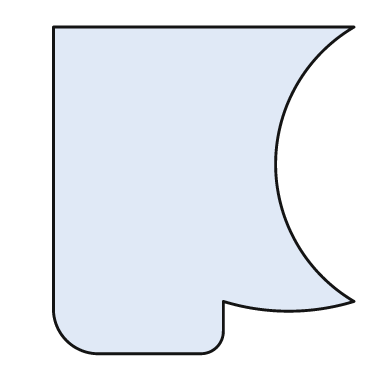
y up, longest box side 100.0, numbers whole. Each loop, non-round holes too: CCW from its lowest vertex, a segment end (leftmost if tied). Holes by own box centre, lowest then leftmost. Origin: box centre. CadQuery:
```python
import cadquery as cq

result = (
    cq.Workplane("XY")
    .moveTo(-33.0, -50.0)
    .lineTo(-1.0, -50.0)
    .threePointArc((4.0, -48.0), (6.0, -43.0))
    .lineTo(6.0, -34.0)
    .threePointArc((26.0, -37.0), (46.0, -34.0))
    .threePointArc((22.0, 8.0), (46.0, 50.0))
    .lineTo(-46.0, 50.0)
    .lineTo(-46.0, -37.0)
    .threePointArc((-42.0, -46.0), (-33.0, -50.0))
    .close()
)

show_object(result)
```